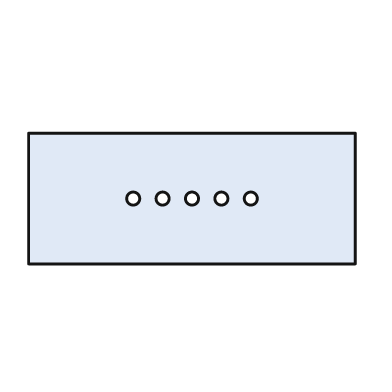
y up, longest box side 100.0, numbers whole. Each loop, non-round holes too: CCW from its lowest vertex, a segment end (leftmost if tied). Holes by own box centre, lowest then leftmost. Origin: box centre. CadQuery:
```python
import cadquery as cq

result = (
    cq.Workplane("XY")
    .moveTo(-50.0, -20.0)
    .lineTo(50.0, -20.0)
    .lineTo(50.0, 20.0)
    .lineTo(-50.0, 20.0)
    .close()
    .moveTo(-18.0, 0.0)
    .circle(2.0)
    .moveTo(-9.0, 0.0)
    .circle(2.0)
    .moveTo(0.0, 0.0)
    .circle(2.0)
    .moveTo(9.0, 0.0)
    .circle(2.0)
    .moveTo(18.0, 0.0)
    .circle(2.0)
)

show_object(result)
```